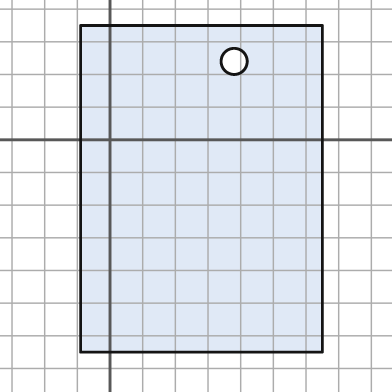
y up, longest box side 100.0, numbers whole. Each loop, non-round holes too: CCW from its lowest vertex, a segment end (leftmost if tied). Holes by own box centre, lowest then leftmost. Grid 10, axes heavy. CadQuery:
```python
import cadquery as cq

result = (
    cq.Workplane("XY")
    .moveTo(-9.0, -65.0)
    .lineTo(65.0, -65.0)
    .lineTo(65.0, 35.0)
    .lineTo(-9.0, 35.0)
    .close()
    .moveTo(38.0, 24.0)
    .circle(4.0)
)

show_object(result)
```